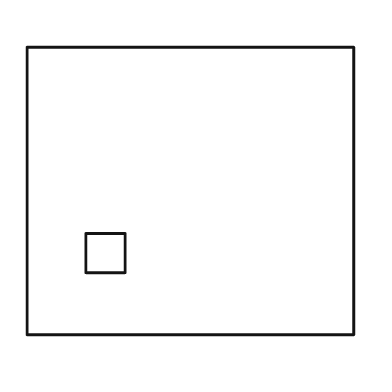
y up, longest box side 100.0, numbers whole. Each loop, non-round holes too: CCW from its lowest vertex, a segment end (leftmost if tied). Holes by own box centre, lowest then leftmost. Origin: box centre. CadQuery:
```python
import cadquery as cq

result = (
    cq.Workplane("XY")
    .moveTo(-50.0, -44.0)
    .lineTo(50.0, -44.0)
    .lineTo(50.0, 44.0)
    .lineTo(-50.0, 44.0)
    .close()
    .moveTo(-32.0, -25.0)
    .lineTo(-20.0, -25.0)
    .lineTo(-20.0, -13.0)
    .lineTo(-32.0, -13.0)
    .close()
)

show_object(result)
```